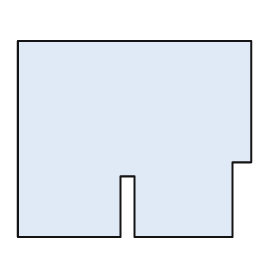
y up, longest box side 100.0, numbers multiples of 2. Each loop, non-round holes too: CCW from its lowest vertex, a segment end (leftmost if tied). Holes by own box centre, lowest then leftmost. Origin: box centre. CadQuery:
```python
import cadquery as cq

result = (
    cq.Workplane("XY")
    .moveTo(-50.0, -42.0)
    .lineTo(-6.0, -42.0)
    .lineTo(-6.0, -16.0)
    .lineTo(0.0, -16.0)
    .lineTo(0.0, -42.0)
    .lineTo(42.0, -42.0)
    .lineTo(42.0, -10.0)
    .lineTo(50.0, -10.0)
    .lineTo(50.0, 42.0)
    .lineTo(-50.0, 42.0)
    .close()
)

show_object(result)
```